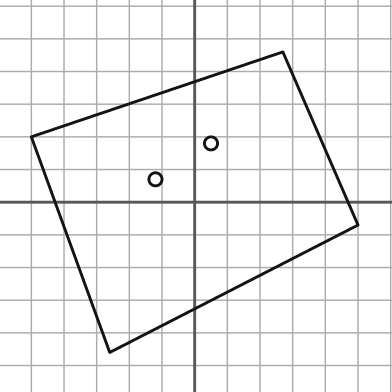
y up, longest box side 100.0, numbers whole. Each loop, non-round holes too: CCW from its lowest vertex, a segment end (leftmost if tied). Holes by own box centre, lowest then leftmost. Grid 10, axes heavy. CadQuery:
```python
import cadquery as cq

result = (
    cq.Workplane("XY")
    .moveTo(-26.0, -46.0)
    .lineTo(50.0, -7.0)
    .lineTo(27.0, 46.0)
    .lineTo(-50.0, 20.0)
    .close()
    .moveTo(-12.0, 7.0)
    .circle(2.0)
    .moveTo(5.0, 18.0)
    .circle(2.0)
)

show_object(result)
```